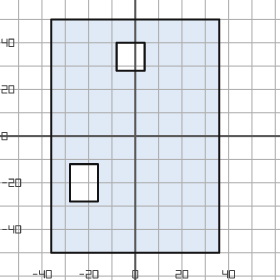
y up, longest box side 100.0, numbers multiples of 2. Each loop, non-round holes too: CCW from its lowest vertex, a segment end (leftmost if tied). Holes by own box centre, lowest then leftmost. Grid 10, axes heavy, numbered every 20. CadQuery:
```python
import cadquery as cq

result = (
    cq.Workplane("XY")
    .moveTo(-36.0, -50.0)
    .lineTo(36.0, -50.0)
    .lineTo(36.0, 50.0)
    .lineTo(-36.0, 50.0)
    .close()
    .moveTo(-28.0, -28.0)
    .lineTo(-16.0, -28.0)
    .lineTo(-16.0, -12.0)
    .lineTo(-28.0, -12.0)
    .close()
    .moveTo(-8.0, 28.0)
    .lineTo(4.0, 28.0)
    .lineTo(4.0, 40.0)
    .lineTo(-8.0, 40.0)
    .close()
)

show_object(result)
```